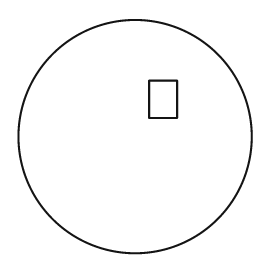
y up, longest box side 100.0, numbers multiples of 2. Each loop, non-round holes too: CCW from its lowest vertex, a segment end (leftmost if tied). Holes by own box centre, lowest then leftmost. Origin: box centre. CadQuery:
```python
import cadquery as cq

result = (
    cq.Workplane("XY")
    .moveTo(0.0, 0.0)
    .circle(50.0)
    .moveTo(6.0, 8.0)
    .lineTo(18.0, 8.0)
    .lineTo(18.0, 24.0)
    .lineTo(6.0, 24.0)
    .close()
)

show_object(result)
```